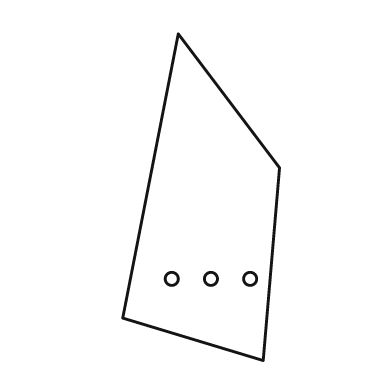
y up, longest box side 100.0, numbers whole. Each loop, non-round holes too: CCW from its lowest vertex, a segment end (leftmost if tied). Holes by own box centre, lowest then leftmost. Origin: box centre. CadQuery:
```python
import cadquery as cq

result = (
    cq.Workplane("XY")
    .moveTo(19.0, -50.0)
    .lineTo(24.0, 9.0)
    .lineTo(-7.0, 50.0)
    .lineTo(-24.0, -37.0)
    .close()
    .moveTo(-9.0, -25.0)
    .circle(2.0)
    .moveTo(3.0, -25.0)
    .circle(2.0)
    .moveTo(15.0, -25.0)
    .circle(2.0)
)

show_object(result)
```